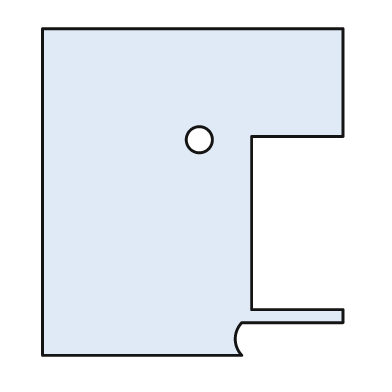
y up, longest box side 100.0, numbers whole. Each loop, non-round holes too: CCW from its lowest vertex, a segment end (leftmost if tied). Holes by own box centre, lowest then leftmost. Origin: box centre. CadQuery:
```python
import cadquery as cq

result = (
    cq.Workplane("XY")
    .moveTo(-46.0, -50.0)
    .lineTo(15.0, -50.0)
    .threePointArc((13.0, -45.0), (15.0, -40.0))
    .lineTo(46.0, -40.0)
    .lineTo(46.0, -36.0)
    .lineTo(18.0, -36.0)
    .lineTo(18.0, 17.0)
    .lineTo(46.0, 17.0)
    .lineTo(46.0, 50.0)
    .lineTo(-46.0, 50.0)
    .close()
    .moveTo(2.0, 16.0)
    .circle(4.0)
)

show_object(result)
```